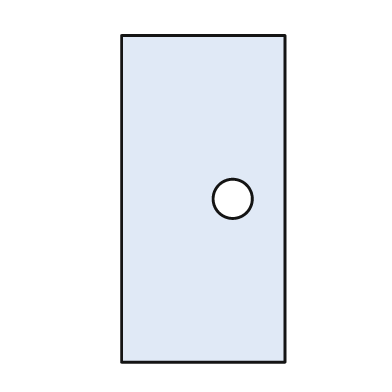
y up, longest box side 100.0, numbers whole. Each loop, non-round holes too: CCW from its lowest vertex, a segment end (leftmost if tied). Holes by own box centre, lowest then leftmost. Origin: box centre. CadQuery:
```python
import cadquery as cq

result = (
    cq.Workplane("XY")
    .moveTo(-25.0, -50.0)
    .lineTo(25.0, -50.0)
    .lineTo(25.0, 50.0)
    .lineTo(-25.0, 50.0)
    .close()
    .moveTo(9.0, 0.0)
    .circle(6.0)
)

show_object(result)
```